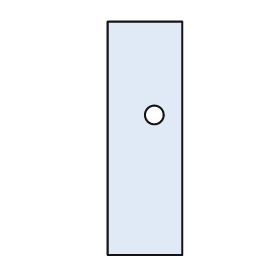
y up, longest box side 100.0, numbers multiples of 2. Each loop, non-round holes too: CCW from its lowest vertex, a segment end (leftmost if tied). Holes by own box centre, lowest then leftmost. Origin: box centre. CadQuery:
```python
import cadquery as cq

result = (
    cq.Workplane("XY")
    .moveTo(-16.0, -50.0)
    .lineTo(16.0, -50.0)
    .lineTo(16.0, 50.0)
    .lineTo(-16.0, 50.0)
    .close()
    .moveTo(4.0, 10.0)
    .circle(4.0)
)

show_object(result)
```